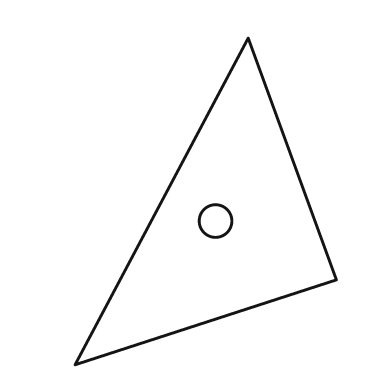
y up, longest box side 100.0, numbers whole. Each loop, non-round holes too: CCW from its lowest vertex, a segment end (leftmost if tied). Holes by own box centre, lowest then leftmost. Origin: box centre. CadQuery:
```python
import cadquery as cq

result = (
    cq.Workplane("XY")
    .moveTo(-40.0, -50.0)
    .lineTo(40.0, -24.0)
    .lineTo(13.0, 50.0)
    .close()
    .moveTo(3.0, -6.0)
    .circle(5.0)
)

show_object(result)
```